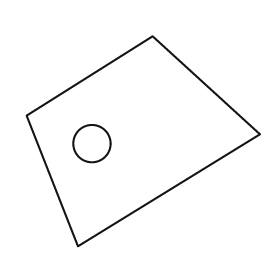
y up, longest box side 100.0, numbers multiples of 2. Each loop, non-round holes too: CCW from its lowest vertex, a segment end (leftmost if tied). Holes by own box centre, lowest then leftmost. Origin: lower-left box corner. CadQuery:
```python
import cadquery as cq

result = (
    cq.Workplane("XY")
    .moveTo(22.0, 0.0)
    .lineTo(100.0, 48.0)
    .lineTo(54.0, 90.0)
    .lineTo(0.0, 56.0)
    .close()
    .moveTo(28.0, 44.0)
    .circle(8.0)
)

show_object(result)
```